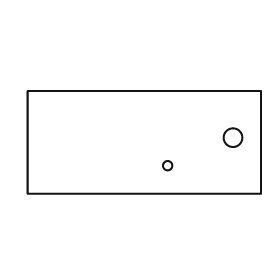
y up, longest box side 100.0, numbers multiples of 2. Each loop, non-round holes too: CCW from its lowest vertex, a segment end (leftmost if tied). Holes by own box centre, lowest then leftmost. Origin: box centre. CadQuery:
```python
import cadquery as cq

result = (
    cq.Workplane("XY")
    .moveTo(-50.0, -22.0)
    .lineTo(50.0, -22.0)
    .lineTo(50.0, 22.0)
    .lineTo(-50.0, 22.0)
    .close()
    .moveTo(10.0, -10.0)
    .circle(2.0)
    .moveTo(38.0, 2.0)
    .circle(4.0)
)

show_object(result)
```